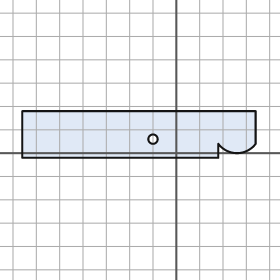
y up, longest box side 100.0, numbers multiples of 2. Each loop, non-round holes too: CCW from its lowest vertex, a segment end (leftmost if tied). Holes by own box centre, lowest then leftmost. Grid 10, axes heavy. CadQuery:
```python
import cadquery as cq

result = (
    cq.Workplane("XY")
    .moveTo(-66.0, -2.0)
    .lineTo(18.0, -2.0)
    .lineTo(18.0, 4.0)
    .threePointArc((26.0, 0.0), (34.0, 4.0))
    .lineTo(34.0, 18.0)
    .lineTo(-66.0, 18.0)
    .close()
    .moveTo(-10.0, 6.0)
    .circle(2.0)
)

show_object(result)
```